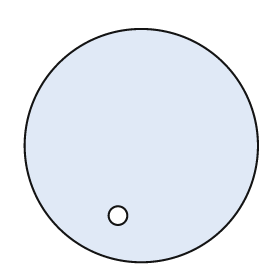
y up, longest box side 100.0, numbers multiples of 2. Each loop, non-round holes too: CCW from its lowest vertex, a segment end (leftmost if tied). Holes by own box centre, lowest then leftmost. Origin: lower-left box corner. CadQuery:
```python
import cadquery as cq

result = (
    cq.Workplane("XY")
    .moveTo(50.0, 50.0)
    .circle(50.0)
    .moveTo(40.0, 20.0)
    .circle(4.0)
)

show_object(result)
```